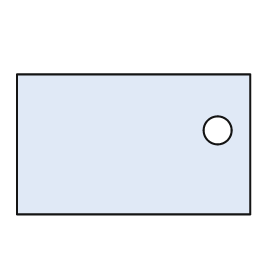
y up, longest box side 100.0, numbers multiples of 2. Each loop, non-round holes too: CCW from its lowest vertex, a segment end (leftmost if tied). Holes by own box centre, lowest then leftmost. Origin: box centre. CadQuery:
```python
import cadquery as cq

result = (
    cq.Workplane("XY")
    .moveTo(-50.0, -30.0)
    .lineTo(50.0, -30.0)
    .lineTo(50.0, 30.0)
    .lineTo(-50.0, 30.0)
    .close()
    .moveTo(36.0, 6.0)
    .circle(6.0)
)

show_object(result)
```